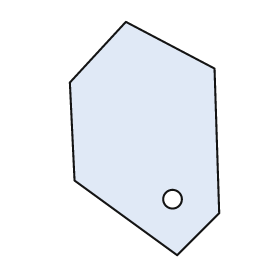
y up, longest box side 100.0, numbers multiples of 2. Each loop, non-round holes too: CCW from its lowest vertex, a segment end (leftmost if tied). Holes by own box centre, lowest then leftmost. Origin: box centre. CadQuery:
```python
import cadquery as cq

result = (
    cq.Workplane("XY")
    .moveTo(14.0, -50.0)
    .lineTo(32.0, -32.0)
    .lineTo(30.0, 30.0)
    .lineTo(-8.0, 50.0)
    .lineTo(-32.0, 24.0)
    .lineTo(-30.0, -18.0)
    .close()
    .moveTo(12.0, -26.0)
    .circle(4.0)
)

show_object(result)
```